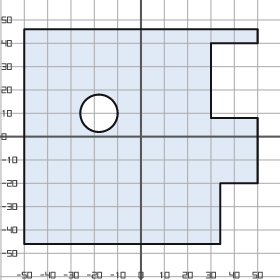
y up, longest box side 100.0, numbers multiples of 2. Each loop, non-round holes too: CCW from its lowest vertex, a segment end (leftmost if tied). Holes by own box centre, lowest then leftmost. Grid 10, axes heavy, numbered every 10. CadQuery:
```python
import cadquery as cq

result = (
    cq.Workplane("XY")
    .moveTo(-50.0, -46.0)
    .lineTo(34.0, -46.0)
    .lineTo(34.0, -20.0)
    .lineTo(50.0, -20.0)
    .lineTo(50.0, 8.0)
    .lineTo(30.0, 8.0)
    .lineTo(30.0, 40.0)
    .lineTo(50.0, 40.0)
    .lineTo(50.0, 46.0)
    .lineTo(-50.0, 46.0)
    .close()
    .moveTo(-18.0, 10.0)
    .circle(8.0)
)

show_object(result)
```